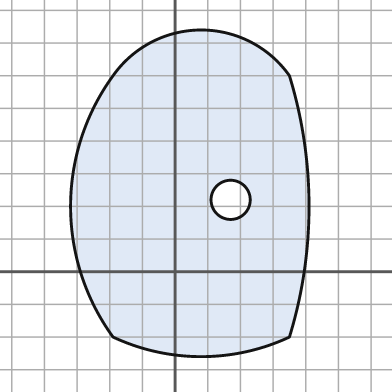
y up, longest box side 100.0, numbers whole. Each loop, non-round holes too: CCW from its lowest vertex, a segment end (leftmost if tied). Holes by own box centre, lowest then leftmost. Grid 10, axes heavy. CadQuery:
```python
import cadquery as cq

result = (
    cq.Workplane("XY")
    .moveTo(-19.0, -20.0)
    .threePointArc((8.0, -26.0), (35.0, -20.0))
    .threePointArc((41.0, 20.0), (35.0, 60.0))
    .threePointArc((8.0, 74.0), (-19.0, 60.0))
    .threePointArc((-32.0, 20.0), (-19.0, -20.0))
    .close()
    .moveTo(17.0, 22.0)
    .circle(6.0)
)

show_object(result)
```